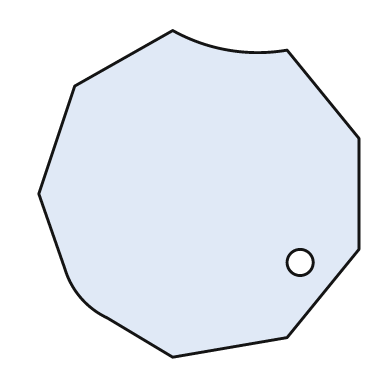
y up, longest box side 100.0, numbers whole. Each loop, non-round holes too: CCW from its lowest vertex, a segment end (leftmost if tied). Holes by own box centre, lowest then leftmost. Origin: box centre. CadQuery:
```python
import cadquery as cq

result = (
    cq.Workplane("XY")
    .moveTo(-8.0, -50.0)
    .lineTo(27.0, -44.0)
    .lineTo(49.0, -17.0)
    .lineTo(49.0, 17.0)
    .lineTo(27.0, 44.0)
    .threePointArc((9.0, 44.0), (-8.0, 50.0))
    .lineTo(-38.0, 33.0)
    .lineTo(-49.0, 0.0)
    .lineTo(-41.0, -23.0)
    .threePointArc((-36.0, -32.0), (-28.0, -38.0))
    .close()
    .moveTo(31.0, -21.0)
    .circle(4.0)
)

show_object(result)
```